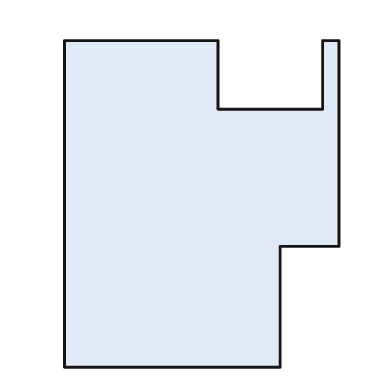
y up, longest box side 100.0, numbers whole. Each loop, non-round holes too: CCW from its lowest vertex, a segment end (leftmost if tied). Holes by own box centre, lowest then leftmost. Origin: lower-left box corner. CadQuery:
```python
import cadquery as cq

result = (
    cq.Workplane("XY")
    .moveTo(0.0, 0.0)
    .lineTo(66.0, 0.0)
    .lineTo(66.0, 37.0)
    .lineTo(84.0, 37.0)
    .lineTo(84.0, 100.0)
    .lineTo(79.0, 100.0)
    .lineTo(79.0, 79.0)
    .lineTo(47.0, 79.0)
    .lineTo(47.0, 100.0)
    .lineTo(0.0, 100.0)
    .close()
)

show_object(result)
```